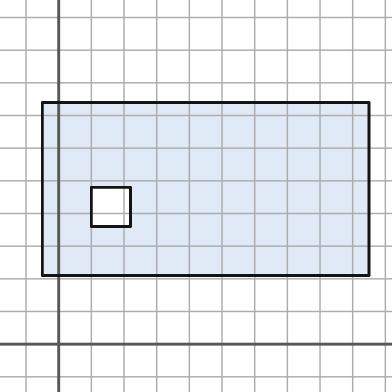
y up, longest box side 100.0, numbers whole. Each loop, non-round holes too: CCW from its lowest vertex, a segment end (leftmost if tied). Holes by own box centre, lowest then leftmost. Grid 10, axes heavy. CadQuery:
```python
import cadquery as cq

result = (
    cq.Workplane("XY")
    .moveTo(-5.0, 21.0)
    .lineTo(95.0, 21.0)
    .lineTo(95.0, 74.0)
    .lineTo(-5.0, 74.0)
    .close()
    .moveTo(10.0, 36.0)
    .lineTo(22.0, 36.0)
    .lineTo(22.0, 48.0)
    .lineTo(10.0, 48.0)
    .close()
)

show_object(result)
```